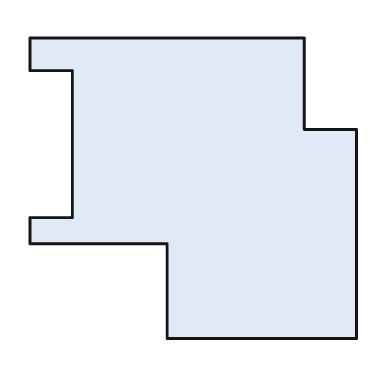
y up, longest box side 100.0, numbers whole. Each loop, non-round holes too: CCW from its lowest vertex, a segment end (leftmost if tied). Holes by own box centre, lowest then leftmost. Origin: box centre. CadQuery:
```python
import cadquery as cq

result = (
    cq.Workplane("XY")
    .moveTo(-8.0, -46.0)
    .lineTo(50.0, -46.0)
    .lineTo(50.0, 18.0)
    .lineTo(34.0, 18.0)
    .lineTo(34.0, 46.0)
    .lineTo(-50.0, 46.0)
    .lineTo(-50.0, 36.0)
    .lineTo(-37.0, 36.0)
    .lineTo(-37.0, -9.0)
    .lineTo(-50.0, -9.0)
    .lineTo(-50.0, -17.0)
    .lineTo(-8.0, -17.0)
    .close()
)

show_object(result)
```